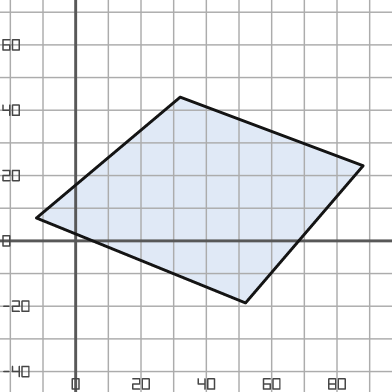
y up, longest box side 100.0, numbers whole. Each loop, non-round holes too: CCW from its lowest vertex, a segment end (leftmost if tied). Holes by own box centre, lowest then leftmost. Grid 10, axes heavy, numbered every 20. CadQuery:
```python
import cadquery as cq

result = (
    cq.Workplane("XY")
    .moveTo(52.0, -19.0)
    .lineTo(88.0, 23.0)
    .lineTo(32.0, 44.0)
    .lineTo(-12.0, 7.0)
    .close()
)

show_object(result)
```